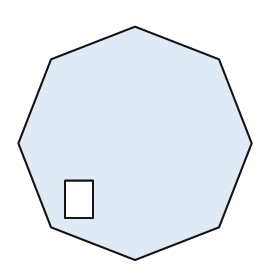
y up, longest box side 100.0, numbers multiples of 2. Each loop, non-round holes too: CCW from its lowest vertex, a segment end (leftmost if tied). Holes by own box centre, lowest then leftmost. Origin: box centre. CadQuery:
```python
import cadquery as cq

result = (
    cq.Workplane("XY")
    .moveTo(0.0, -50.0)
    .lineTo(36.0, -36.0)
    .lineTo(50.0, 0.0)
    .lineTo(36.0, 36.0)
    .lineTo(0.0, 50.0)
    .lineTo(-36.0, 36.0)
    .lineTo(-50.0, 0.0)
    .lineTo(-36.0, -36.0)
    .close()
    .moveTo(-30.0, -32.0)
    .lineTo(-18.0, -32.0)
    .lineTo(-18.0, -16.0)
    .lineTo(-30.0, -16.0)
    .close()
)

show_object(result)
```